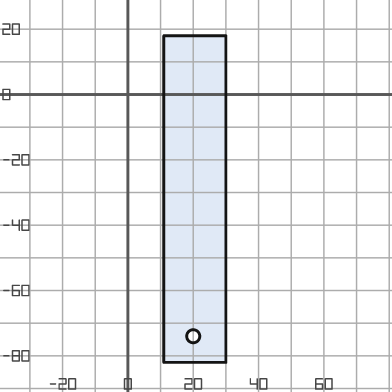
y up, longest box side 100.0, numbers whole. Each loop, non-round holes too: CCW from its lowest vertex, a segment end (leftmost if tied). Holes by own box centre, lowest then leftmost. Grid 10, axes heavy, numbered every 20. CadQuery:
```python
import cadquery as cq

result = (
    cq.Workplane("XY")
    .moveTo(11.0, -82.0)
    .lineTo(30.0, -82.0)
    .lineTo(30.0, 18.0)
    .lineTo(11.0, 18.0)
    .close()
    .moveTo(20.0, -74.0)
    .circle(2.0)
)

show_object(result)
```